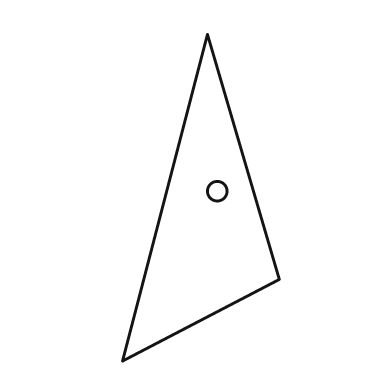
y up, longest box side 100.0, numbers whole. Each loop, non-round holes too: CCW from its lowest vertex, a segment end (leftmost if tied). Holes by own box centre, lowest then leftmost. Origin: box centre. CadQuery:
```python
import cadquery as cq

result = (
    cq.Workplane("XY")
    .moveTo(-24.0, -50.0)
    .lineTo(24.0, -25.0)
    .lineTo(2.0, 50.0)
    .close()
    .moveTo(5.0, 2.0)
    .circle(3.0)
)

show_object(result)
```